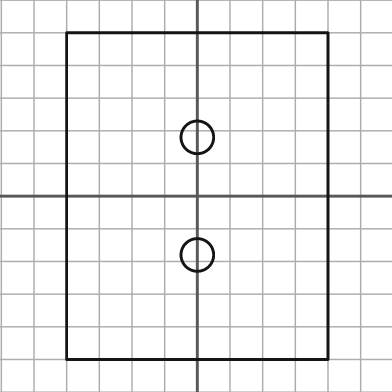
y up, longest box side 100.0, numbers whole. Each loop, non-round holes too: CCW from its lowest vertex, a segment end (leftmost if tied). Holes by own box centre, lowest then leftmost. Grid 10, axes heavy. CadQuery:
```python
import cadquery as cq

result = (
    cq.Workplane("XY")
    .moveTo(-40.0, -50.0)
    .lineTo(40.0, -50.0)
    .lineTo(40.0, 50.0)
    .lineTo(-40.0, 50.0)
    .close()
    .moveTo(0.0, -18.0)
    .circle(5.0)
    .moveTo(0.0, 18.0)
    .circle(5.0)
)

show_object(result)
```